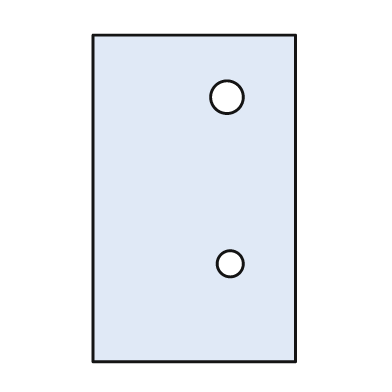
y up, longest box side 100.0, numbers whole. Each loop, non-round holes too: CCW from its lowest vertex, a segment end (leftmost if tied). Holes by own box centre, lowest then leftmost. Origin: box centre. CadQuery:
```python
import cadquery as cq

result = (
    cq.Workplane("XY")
    .moveTo(-31.0, -50.0)
    .lineTo(31.0, -50.0)
    .lineTo(31.0, 50.0)
    .lineTo(-31.0, 50.0)
    .close()
    .moveTo(11.0, -20.0)
    .circle(4.0)
    .moveTo(10.0, 31.0)
    .circle(5.0)
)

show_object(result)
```